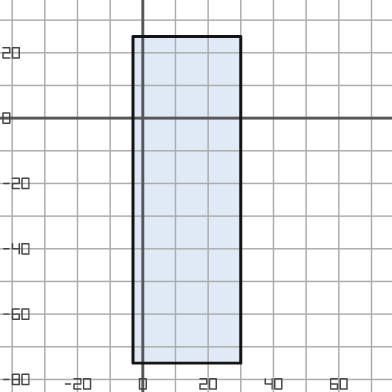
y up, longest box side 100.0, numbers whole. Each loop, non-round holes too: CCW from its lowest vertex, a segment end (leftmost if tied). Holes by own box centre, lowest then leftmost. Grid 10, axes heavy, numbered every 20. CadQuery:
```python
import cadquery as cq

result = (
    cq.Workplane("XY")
    .moveTo(-3.0, -75.0)
    .lineTo(30.0, -75.0)
    .lineTo(30.0, 25.0)
    .lineTo(-3.0, 25.0)
    .close()
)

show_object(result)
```